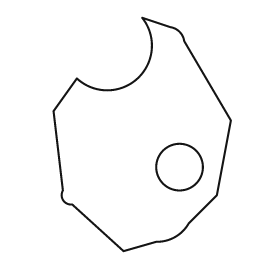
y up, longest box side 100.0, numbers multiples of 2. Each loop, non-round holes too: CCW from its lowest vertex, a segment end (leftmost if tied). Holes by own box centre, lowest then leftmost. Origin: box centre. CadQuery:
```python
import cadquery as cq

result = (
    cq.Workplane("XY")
    .moveTo(-8.0, -50.0)
    .lineTo(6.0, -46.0)
    .threePointArc((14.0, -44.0), (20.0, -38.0))
    .lineTo(32.0, -26.0)
    .lineTo(38.0, 6.0)
    .lineTo(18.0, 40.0)
    .threePointArc((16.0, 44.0), (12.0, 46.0))
    .lineTo(0.0, 50.0)
    .threePointArc((-2.0, 24.0), (-28.0, 24.0))
    .lineTo(-38.0, 10.0)
    .lineTo(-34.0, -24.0)
    .threePointArc((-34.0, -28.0), (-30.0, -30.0))
    .close()
    .moveTo(16.0, -14.0)
    .circle(10.0)
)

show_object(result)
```